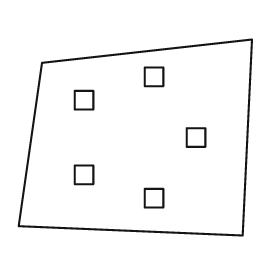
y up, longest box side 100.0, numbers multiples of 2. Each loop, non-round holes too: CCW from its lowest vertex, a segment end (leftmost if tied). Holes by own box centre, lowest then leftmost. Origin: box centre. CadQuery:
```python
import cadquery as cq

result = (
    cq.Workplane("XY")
    .moveTo(46.0, -42.0)
    .lineTo(50.0, 42.0)
    .lineTo(-40.0, 32.0)
    .lineTo(-50.0, -38.0)
    .close()
    .moveTo(4.0, -30.0)
    .lineTo(12.0, -30.0)
    .lineTo(12.0, -22.0)
    .lineTo(4.0, -22.0)
    .close()
    .moveTo(-26.0, -20.0)
    .lineTo(-18.0, -20.0)
    .lineTo(-18.0, -12.0)
    .lineTo(-26.0, -12.0)
    .close()
    .moveTo(22.0, -4.0)
    .lineTo(30.0, -4.0)
    .lineTo(30.0, 4.0)
    .lineTo(22.0, 4.0)
    .close()
    .moveTo(-26.0, 12.0)
    .lineTo(-18.0, 12.0)
    .lineTo(-18.0, 20.0)
    .lineTo(-26.0, 20.0)
    .close()
    .moveTo(4.0, 22.0)
    .lineTo(12.0, 22.0)
    .lineTo(12.0, 30.0)
    .lineTo(4.0, 30.0)
    .close()
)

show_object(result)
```